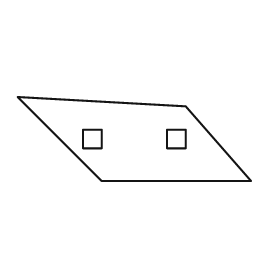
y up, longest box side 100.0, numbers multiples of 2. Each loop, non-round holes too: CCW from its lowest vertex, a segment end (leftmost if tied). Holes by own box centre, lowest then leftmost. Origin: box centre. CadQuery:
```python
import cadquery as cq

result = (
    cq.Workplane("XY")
    .moveTo(-14.0, -18.0)
    .lineTo(50.0, -18.0)
    .lineTo(22.0, 14.0)
    .lineTo(-50.0, 18.0)
    .close()
    .moveTo(-22.0, -4.0)
    .lineTo(-14.0, -4.0)
    .lineTo(-14.0, 4.0)
    .lineTo(-22.0, 4.0)
    .close()
    .moveTo(14.0, -4.0)
    .lineTo(22.0, -4.0)
    .lineTo(22.0, 4.0)
    .lineTo(14.0, 4.0)
    .close()
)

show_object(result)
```